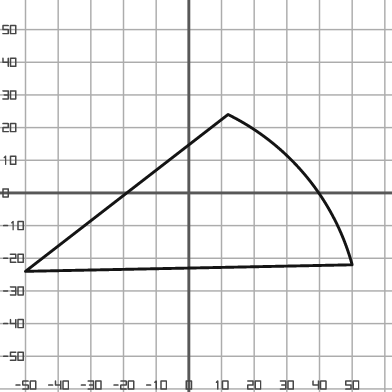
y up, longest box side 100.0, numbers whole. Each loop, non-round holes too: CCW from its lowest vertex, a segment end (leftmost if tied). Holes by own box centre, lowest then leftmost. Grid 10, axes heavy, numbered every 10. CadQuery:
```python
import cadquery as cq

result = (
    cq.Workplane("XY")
    .moveTo(-50.0, -24.0)
    .lineTo(50.0, -22.0)
    .threePointArc((36.0, 5.0), (12.0, 24.0))
    .close()
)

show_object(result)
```